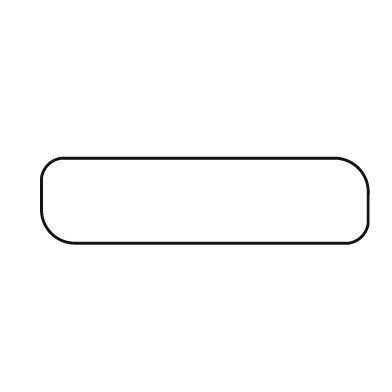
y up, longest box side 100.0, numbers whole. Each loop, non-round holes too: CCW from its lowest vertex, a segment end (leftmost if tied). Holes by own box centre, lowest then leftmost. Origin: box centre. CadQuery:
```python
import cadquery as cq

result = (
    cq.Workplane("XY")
    .moveTo(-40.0, -13.0)
    .lineTo(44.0, -13.0)
    .threePointArc((48.0, -11.0), (50.0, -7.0))
    .lineTo(50.0, 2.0)
    .threePointArc((47.0, 10.0), (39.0, 13.0))
    .lineTo(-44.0, 13.0)
    .threePointArc((-48.0, 11.0), (-50.0, 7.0))
    .lineTo(-50.0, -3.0)
    .threePointArc((-47.0, -10.0), (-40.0, -13.0))
    .close()
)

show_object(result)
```